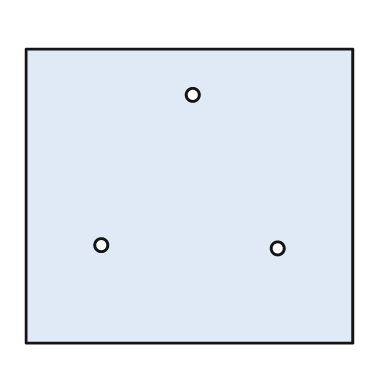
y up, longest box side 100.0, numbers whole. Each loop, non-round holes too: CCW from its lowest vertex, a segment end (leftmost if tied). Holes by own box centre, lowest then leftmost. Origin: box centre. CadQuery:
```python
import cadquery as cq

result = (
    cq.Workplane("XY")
    .moveTo(-50.0, -45.0)
    .lineTo(50.0, -45.0)
    .lineTo(50.0, 45.0)
    .lineTo(-50.0, 45.0)
    .close()
    .moveTo(27.0, -16.0)
    .circle(2.0)
    .moveTo(-27.0, -15.0)
    .circle(2.0)
    .moveTo(1.0, 31.0)
    .circle(2.0)
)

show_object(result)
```